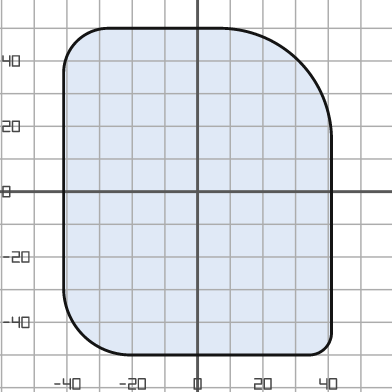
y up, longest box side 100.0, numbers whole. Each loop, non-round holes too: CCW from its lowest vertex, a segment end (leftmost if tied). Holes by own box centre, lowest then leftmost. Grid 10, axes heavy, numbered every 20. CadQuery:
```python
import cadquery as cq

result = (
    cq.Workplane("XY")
    .moveTo(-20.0, -50.0)
    .lineTo(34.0, -50.0)
    .threePointArc((39.0, -48.0), (41.0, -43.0))
    .lineTo(41.0, 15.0)
    .threePointArc((31.0, 40.0), (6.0, 50.0))
    .lineTo(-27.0, 50.0)
    .threePointArc((-37.0, 46.0), (-41.0, 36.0))
    .lineTo(-41.0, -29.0)
    .threePointArc((-35.0, -44.0), (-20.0, -50.0))
    .close()
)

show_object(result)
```